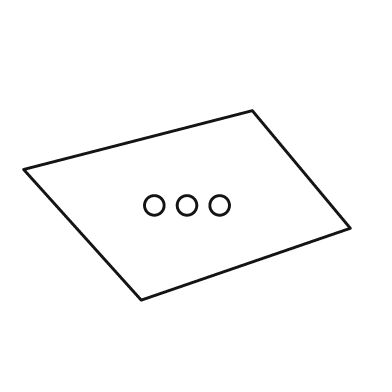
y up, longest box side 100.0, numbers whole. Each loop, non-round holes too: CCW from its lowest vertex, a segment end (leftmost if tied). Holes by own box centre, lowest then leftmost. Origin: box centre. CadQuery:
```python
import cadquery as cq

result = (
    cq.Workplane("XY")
    .moveTo(-14.0, -29.0)
    .lineTo(50.0, -7.0)
    .lineTo(20.0, 29.0)
    .lineTo(-50.0, 11.0)
    .close()
    .moveTo(-10.0, 0.0)
    .circle(3.0)
    .moveTo(0.0, 0.0)
    .circle(3.0)
    .moveTo(10.0, 0.0)
    .circle(3.0)
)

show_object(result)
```